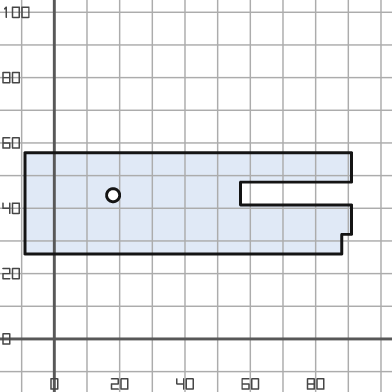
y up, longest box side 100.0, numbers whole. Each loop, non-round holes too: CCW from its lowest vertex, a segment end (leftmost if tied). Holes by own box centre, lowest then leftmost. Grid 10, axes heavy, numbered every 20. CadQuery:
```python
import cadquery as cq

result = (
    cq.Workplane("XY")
    .moveTo(-9.0, 26.0)
    .lineTo(88.0, 26.0)
    .lineTo(88.0, 32.0)
    .lineTo(91.0, 32.0)
    .lineTo(91.0, 41.0)
    .lineTo(57.0, 41.0)
    .lineTo(57.0, 48.0)
    .lineTo(91.0, 48.0)
    .lineTo(91.0, 57.0)
    .lineTo(-9.0, 57.0)
    .close()
    .moveTo(18.0, 44.0)
    .circle(2.0)
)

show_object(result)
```